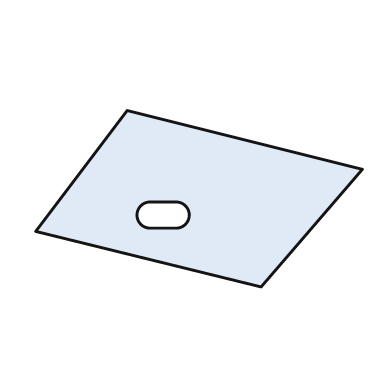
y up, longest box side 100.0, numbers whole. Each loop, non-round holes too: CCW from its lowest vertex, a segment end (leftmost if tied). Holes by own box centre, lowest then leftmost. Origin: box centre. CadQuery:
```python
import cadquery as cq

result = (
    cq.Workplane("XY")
    .moveTo(19.0, -27.0)
    .lineTo(50.0, 9.0)
    .lineTo(-22.0, 27.0)
    .lineTo(-50.0, -10.0)
    .close()
    .moveTo(-15.0, -9.0)
    .lineTo(-7.0, -9.0)
    .threePointArc((-3.0, -5.0), (-7.0, -1.0))
    .lineTo(-15.0, -1.0)
    .threePointArc((-19.0, -5.0), (-15.0, -9.0))
    .close()
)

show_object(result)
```